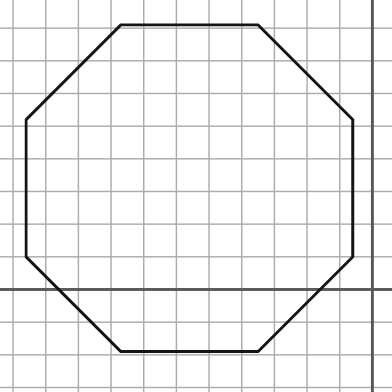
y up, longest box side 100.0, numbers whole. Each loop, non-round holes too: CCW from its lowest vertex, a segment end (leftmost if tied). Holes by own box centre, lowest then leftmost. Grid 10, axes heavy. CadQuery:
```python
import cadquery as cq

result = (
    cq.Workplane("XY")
    .moveTo(-77.0, -19.0)
    .lineTo(-35.0, -19.0)
    .lineTo(-6.0, 10.0)
    .lineTo(-6.0, 52.0)
    .lineTo(-35.0, 81.0)
    .lineTo(-77.0, 81.0)
    .lineTo(-106.0, 52.0)
    .lineTo(-106.0, 10.0)
    .close()
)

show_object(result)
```